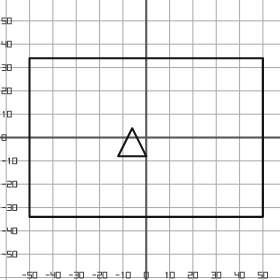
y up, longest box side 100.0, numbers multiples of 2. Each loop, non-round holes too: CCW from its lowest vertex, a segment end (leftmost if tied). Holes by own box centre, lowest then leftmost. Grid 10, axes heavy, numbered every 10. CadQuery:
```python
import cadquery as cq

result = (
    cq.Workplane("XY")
    .moveTo(-50.0, -34.0)
    .lineTo(50.0, -34.0)
    .lineTo(50.0, 34.0)
    .lineTo(-50.0, 34.0)
    .close()
    .moveTo(-12.0, -8.0)
    .lineTo(0.0, -8.0)
    .lineTo(-6.0, 4.0)
    .close()
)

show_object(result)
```